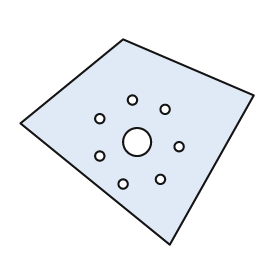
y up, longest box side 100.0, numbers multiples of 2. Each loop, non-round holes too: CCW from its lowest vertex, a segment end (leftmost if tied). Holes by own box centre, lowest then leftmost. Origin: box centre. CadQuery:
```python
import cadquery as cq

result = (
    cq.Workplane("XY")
    .moveTo(14.0, -44.0)
    .lineTo(50.0, 20.0)
    .lineTo(-6.0, 44.0)
    .lineTo(-50.0, 8.0)
    .close()
    .moveTo(-6.0, -18.0)
    .circle(2.0)
    .moveTo(10.0, -16.0)
    .circle(2.0)
    .moveTo(-16.0, -6.0)
    .circle(2.0)
    .moveTo(18.0, -2.0)
    .circle(2.0)
    .moveTo(0.0, 0.0)
    .circle(6.0)
    .moveTo(-16.0, 10.0)
    .circle(2.0)
    .moveTo(12.0, 14.0)
    .circle(2.0)
    .moveTo(-2.0, 18.0)
    .circle(2.0)
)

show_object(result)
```